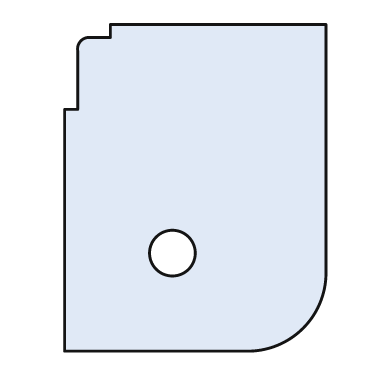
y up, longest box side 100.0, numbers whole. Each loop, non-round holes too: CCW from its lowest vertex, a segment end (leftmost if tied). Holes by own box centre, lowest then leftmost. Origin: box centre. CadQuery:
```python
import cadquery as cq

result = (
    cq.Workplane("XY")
    .moveTo(-40.0, -50.0)
    .lineTo(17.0, -50.0)
    .threePointArc((33.0, -43.0), (40.0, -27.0))
    .lineTo(40.0, 50.0)
    .lineTo(-26.0, 50.0)
    .lineTo(-26.0, 46.0)
    .lineTo(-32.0, 46.0)
    .threePointArc((-35.0, 45.0), (-36.0, 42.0))
    .lineTo(-36.0, 24.0)
    .lineTo(-40.0, 24.0)
    .close()
    .moveTo(-7.0, -20.0)
    .circle(7.0)
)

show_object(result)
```